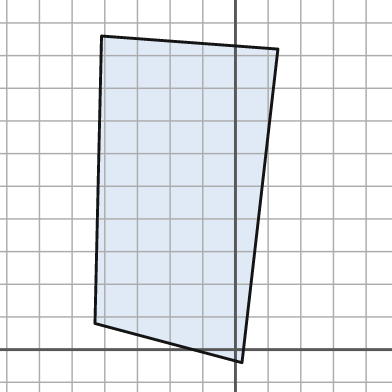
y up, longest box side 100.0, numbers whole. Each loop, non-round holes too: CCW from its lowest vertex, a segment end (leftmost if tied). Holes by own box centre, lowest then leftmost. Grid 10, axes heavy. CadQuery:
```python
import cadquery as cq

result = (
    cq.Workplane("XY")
    .moveTo(2.0, -4.0)
    .lineTo(13.0, 92.0)
    .lineTo(-41.0, 96.0)
    .lineTo(-43.0, 8.0)
    .close()
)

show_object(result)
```